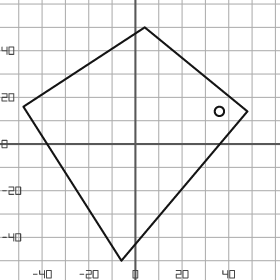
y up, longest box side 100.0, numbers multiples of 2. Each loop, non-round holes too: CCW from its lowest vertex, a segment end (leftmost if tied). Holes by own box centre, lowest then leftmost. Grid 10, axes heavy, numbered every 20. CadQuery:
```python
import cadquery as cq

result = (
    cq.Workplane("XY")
    .moveTo(-6.0, -50.0)
    .lineTo(48.0, 14.0)
    .lineTo(4.0, 50.0)
    .lineTo(-48.0, 16.0)
    .close()
    .moveTo(36.0, 14.0)
    .circle(2.0)
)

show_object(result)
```